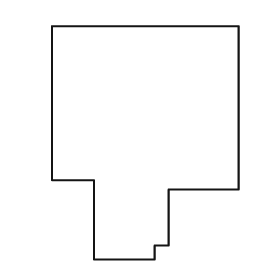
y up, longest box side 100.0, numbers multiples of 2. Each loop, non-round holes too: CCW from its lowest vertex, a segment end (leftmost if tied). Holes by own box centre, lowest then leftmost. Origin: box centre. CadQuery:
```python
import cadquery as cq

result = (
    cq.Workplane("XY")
    .moveTo(-22.0, -50.0)
    .lineTo(4.0, -50.0)
    .lineTo(4.0, -44.0)
    .lineTo(10.0, -44.0)
    .lineTo(10.0, -20.0)
    .lineTo(40.0, -20.0)
    .lineTo(40.0, 50.0)
    .lineTo(-40.0, 50.0)
    .lineTo(-40.0, -16.0)
    .lineTo(-22.0, -16.0)
    .close()
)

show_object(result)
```